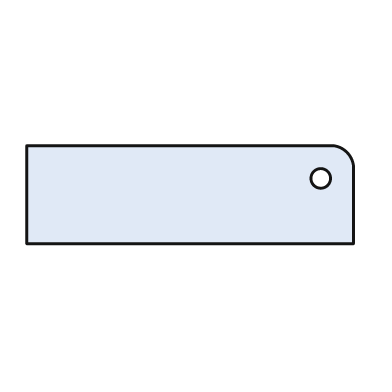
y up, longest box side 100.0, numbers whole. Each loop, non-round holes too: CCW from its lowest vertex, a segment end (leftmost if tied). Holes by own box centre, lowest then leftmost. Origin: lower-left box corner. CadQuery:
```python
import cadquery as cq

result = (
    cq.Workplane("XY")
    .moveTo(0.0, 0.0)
    .lineTo(100.0, 0.0)
    .lineTo(100.0, 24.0)
    .threePointArc((98.0, 28.0), (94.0, 30.0))
    .lineTo(0.0, 30.0)
    .close()
    .moveTo(90.0, 20.0)
    .circle(3.0)
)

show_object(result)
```